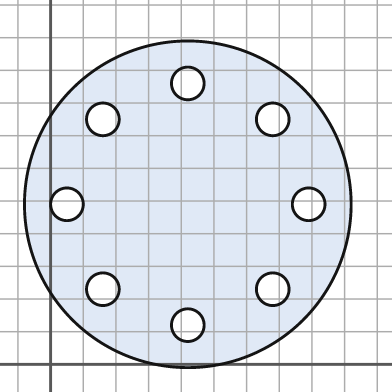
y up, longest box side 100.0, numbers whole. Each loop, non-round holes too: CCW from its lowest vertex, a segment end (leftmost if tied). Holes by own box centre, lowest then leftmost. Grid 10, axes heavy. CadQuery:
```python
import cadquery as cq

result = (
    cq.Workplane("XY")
    .moveTo(42.0, 49.0)
    .circle(50.0)
    .moveTo(42.0, 12.0)
    .circle(5.0)
    .moveTo(16.0, 23.0)
    .circle(5.0)
    .moveTo(68.0, 23.0)
    .circle(5.0)
    .moveTo(5.0, 49.0)
    .circle(5.0)
    .moveTo(79.0, 49.0)
    .circle(5.0)
    .moveTo(16.0, 75.0)
    .circle(5.0)
    .moveTo(68.0, 75.0)
    .circle(5.0)
    .moveTo(42.0, 86.0)
    .circle(5.0)
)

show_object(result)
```